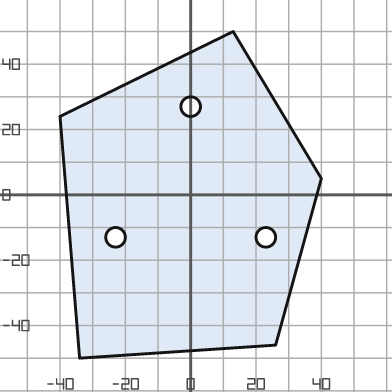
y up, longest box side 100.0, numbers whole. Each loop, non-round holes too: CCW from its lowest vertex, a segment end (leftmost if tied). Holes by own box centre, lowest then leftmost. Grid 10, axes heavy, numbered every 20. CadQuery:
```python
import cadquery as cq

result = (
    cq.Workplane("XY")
    .moveTo(-34.0, -50.0)
    .lineTo(26.0, -46.0)
    .lineTo(40.0, 5.0)
    .lineTo(13.0, 50.0)
    .lineTo(-40.0, 24.0)
    .close()
    .moveTo(-23.0, -13.0)
    .circle(3.0)
    .moveTo(23.0, -13.0)
    .circle(3.0)
    .moveTo(0.0, 27.0)
    .circle(3.0)
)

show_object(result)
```